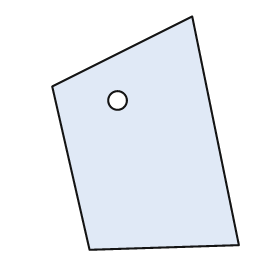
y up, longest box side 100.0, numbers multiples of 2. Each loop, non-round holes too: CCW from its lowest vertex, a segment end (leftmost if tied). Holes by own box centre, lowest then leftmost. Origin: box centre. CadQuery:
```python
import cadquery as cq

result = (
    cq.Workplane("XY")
    .moveTo(-24.0, -50.0)
    .lineTo(40.0, -48.0)
    .lineTo(20.0, 50.0)
    .lineTo(-40.0, 20.0)
    .close()
    .moveTo(-12.0, 14.0)
    .circle(4.0)
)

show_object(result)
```